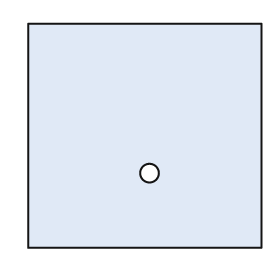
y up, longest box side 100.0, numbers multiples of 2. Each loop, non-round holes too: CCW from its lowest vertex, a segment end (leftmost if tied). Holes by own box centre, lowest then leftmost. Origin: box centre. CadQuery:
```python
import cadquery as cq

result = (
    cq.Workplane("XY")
    .moveTo(-50.0, -48.0)
    .lineTo(50.0, -48.0)
    .lineTo(50.0, 48.0)
    .lineTo(-50.0, 48.0)
    .close()
    .moveTo(2.0, -16.0)
    .circle(4.0)
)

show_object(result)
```